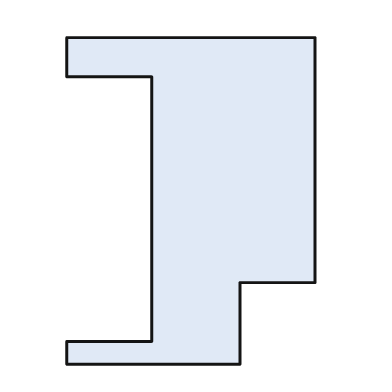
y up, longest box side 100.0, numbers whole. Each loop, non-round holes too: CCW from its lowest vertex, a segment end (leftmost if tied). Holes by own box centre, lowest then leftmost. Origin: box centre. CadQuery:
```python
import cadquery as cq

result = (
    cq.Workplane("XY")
    .moveTo(-38.0, -50.0)
    .lineTo(15.0, -50.0)
    .lineTo(15.0, -25.0)
    .lineTo(38.0, -25.0)
    .lineTo(38.0, 50.0)
    .lineTo(-38.0, 50.0)
    .lineTo(-38.0, 38.0)
    .lineTo(-12.0, 38.0)
    .lineTo(-12.0, -43.0)
    .lineTo(-38.0, -43.0)
    .close()
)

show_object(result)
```